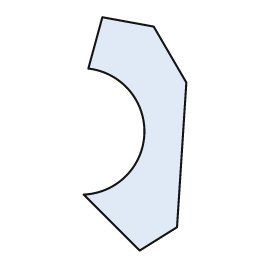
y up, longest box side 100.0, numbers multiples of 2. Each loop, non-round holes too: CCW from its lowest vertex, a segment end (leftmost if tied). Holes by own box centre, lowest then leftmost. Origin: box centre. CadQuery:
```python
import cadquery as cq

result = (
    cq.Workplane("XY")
    .moveTo(2.0, -50.0)
    .lineTo(18.0, -40.0)
    .lineTo(22.0, 22.0)
    .lineTo(8.0, 46.0)
    .lineTo(-14.0, 50.0)
    .lineTo(-20.0, 28.0)
    .threePointArc((4.0, 0.0), (-22.0, -26.0))
    .close()
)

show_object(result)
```